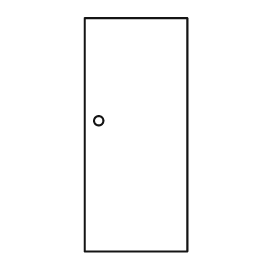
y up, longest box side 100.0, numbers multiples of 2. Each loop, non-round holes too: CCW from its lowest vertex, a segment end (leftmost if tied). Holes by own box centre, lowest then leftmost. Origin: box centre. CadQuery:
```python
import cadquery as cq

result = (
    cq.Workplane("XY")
    .moveTo(-22.0, -50.0)
    .lineTo(22.0, -50.0)
    .lineTo(22.0, 50.0)
    .lineTo(-22.0, 50.0)
    .close()
    .moveTo(-16.0, 6.0)
    .circle(2.0)
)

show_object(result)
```